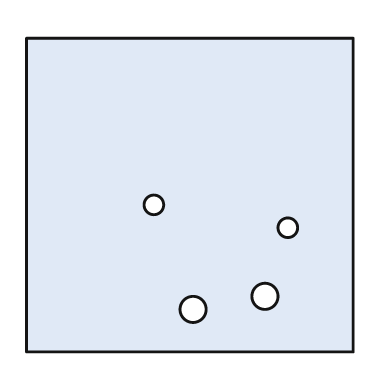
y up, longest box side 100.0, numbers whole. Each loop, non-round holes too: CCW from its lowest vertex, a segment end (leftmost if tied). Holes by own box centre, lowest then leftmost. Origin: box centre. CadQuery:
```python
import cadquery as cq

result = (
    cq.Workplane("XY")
    .moveTo(-50.0, -48.0)
    .lineTo(50.0, -48.0)
    .lineTo(50.0, 48.0)
    .lineTo(-50.0, 48.0)
    .close()
    .moveTo(1.0, -35.0)
    .circle(4.0)
    .moveTo(23.0, -31.0)
    .circle(4.0)
    .moveTo(30.0, -10.0)
    .circle(3.0)
    .moveTo(-11.0, -3.0)
    .circle(3.0)
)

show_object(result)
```